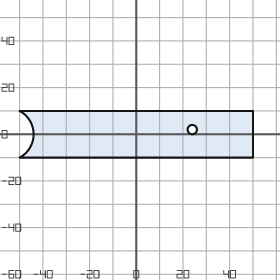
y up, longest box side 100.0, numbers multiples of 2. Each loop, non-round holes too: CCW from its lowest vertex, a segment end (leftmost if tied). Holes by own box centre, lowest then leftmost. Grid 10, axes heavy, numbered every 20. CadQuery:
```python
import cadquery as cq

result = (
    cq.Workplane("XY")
    .moveTo(-50.0, -10.0)
    .lineTo(50.0, -10.0)
    .lineTo(50.0, 10.0)
    .lineTo(-50.0, 10.0)
    .threePointArc((-44.0, 0.0), (-50.0, -10.0))
    .close()
    .moveTo(24.0, 2.0)
    .circle(2.0)
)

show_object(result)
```